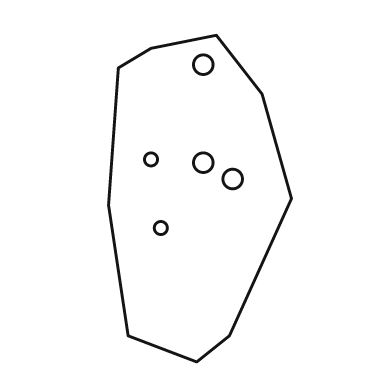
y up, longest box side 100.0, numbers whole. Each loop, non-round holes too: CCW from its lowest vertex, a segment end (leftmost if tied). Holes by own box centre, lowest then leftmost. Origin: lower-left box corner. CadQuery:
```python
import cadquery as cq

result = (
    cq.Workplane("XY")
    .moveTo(27.0, 0.0)
    .lineTo(37.0, 8.0)
    .lineTo(56.0, 50.0)
    .lineTo(47.0, 82.0)
    .lineTo(33.0, 100.0)
    .lineTo(13.0, 96.0)
    .lineTo(3.0, 90.0)
    .lineTo(0.0, 48.0)
    .lineTo(6.0, 8.0)
    .close()
    .moveTo(16.0, 41.0)
    .circle(2.0)
    .moveTo(38.0, 56.0)
    .circle(3.0)
    .moveTo(29.0, 61.0)
    .circle(3.0)
    .moveTo(13.0, 62.0)
    .circle(2.0)
    .moveTo(29.0, 91.0)
    .circle(3.0)
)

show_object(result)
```